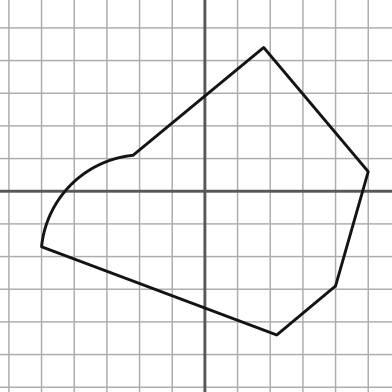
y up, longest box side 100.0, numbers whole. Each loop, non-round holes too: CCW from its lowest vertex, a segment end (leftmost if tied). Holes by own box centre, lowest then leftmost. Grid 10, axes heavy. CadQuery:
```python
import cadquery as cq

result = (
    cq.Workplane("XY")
    .moveTo(22.0, -44.0)
    .lineTo(40.0, -29.0)
    .lineTo(50.0, 6.0)
    .lineTo(18.0, 44.0)
    .lineTo(-22.0, 11.0)
    .threePointArc((-41.0, 2.0), (-50.0, -17.0))
    .close()
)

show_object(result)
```